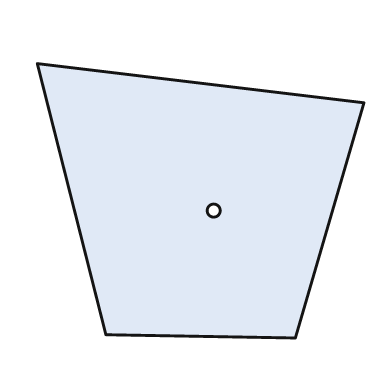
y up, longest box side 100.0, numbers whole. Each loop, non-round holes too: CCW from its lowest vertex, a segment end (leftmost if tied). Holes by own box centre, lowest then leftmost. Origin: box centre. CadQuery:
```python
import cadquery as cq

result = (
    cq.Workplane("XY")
    .moveTo(29.0, -42.0)
    .lineTo(50.0, 30.0)
    .lineTo(-50.0, 42.0)
    .lineTo(-29.0, -41.0)
    .close()
    .moveTo(4.0, -3.0)
    .circle(2.0)
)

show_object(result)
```